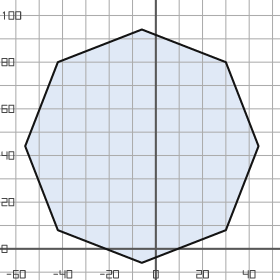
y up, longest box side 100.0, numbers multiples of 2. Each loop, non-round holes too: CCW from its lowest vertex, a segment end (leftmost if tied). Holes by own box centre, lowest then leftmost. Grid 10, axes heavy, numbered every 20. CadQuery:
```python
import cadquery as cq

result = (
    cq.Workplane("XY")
    .moveTo(-6.0, -6.0)
    .lineTo(30.0, 8.0)
    .lineTo(44.0, 44.0)
    .lineTo(30.0, 80.0)
    .lineTo(-6.0, 94.0)
    .lineTo(-42.0, 80.0)
    .lineTo(-56.0, 44.0)
    .lineTo(-42.0, 8.0)
    .close()
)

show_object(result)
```